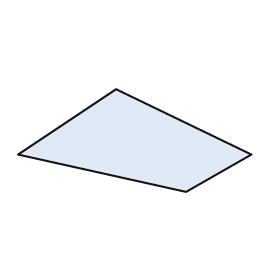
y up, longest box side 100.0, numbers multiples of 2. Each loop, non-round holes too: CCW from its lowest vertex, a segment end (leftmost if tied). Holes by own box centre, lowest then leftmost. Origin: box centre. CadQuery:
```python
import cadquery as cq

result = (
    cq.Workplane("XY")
    .moveTo(22.0, -22.0)
    .lineTo(50.0, -6.0)
    .lineTo(-8.0, 22.0)
    .lineTo(-50.0, -6.0)
    .close()
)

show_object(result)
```